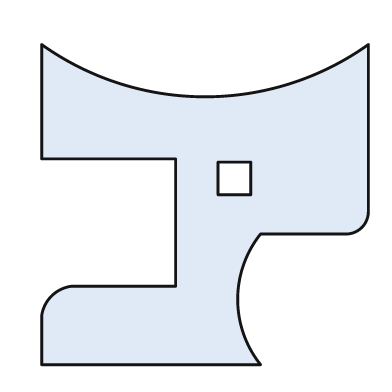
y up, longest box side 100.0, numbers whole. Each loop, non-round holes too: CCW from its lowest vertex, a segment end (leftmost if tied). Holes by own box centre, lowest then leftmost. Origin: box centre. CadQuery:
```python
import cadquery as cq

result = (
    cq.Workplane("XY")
    .moveTo(-50.0, -49.0)
    .lineTo(17.0, -49.0)
    .threePointArc((10.0, -29.0), (17.0, -9.0))
    .lineTo(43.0, -9.0)
    .threePointArc((48.0, -7.0), (50.0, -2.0))
    .lineTo(50.0, 49.0)
    .threePointArc((0.0, 33.0), (-50.0, 49.0))
    .lineTo(-50.0, 14.0)
    .lineTo(-9.0, 14.0)
    .lineTo(-9.0, -25.0)
    .lineTo(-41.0, -25.0)
    .threePointArc((-47.0, -28.0), (-50.0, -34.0))
    .close()
    .moveTo(4.0, 3.0)
    .lineTo(14.0, 3.0)
    .lineTo(14.0, 13.0)
    .lineTo(4.0, 13.0)
    .close()
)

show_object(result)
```